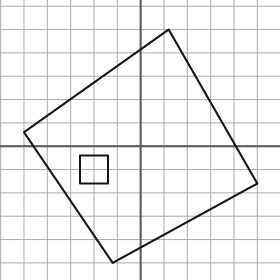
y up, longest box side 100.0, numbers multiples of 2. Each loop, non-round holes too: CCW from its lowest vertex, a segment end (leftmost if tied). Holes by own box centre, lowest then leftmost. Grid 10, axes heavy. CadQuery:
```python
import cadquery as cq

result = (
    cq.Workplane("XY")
    .moveTo(-12.0, -50.0)
    .lineTo(50.0, -16.0)
    .lineTo(12.0, 50.0)
    .lineTo(-50.0, 6.0)
    .close()
    .moveTo(-26.0, -16.0)
    .lineTo(-14.0, -16.0)
    .lineTo(-14.0, -4.0)
    .lineTo(-26.0, -4.0)
    .close()
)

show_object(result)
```